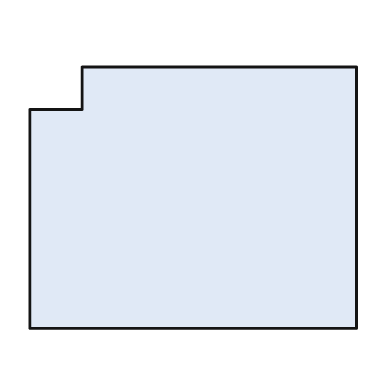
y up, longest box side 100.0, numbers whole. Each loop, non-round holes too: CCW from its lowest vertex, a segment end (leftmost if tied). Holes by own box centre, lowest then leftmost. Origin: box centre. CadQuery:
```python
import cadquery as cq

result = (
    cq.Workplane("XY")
    .moveTo(-50.0, -40.0)
    .lineTo(50.0, -40.0)
    .lineTo(50.0, 40.0)
    .lineTo(-34.0, 40.0)
    .lineTo(-34.0, 27.0)
    .lineTo(-50.0, 27.0)
    .close()
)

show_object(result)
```